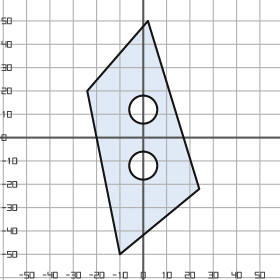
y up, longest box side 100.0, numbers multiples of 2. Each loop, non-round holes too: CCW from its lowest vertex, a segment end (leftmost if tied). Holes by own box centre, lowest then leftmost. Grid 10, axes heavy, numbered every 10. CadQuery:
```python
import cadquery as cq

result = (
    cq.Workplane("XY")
    .moveTo(-10.0, -50.0)
    .lineTo(24.0, -22.0)
    .lineTo(2.0, 50.0)
    .lineTo(-24.0, 20.0)
    .close()
    .moveTo(0.0, -12.0)
    .circle(6.0)
    .moveTo(0.0, 12.0)
    .circle(6.0)
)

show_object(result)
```